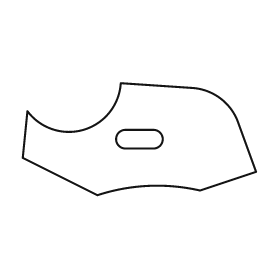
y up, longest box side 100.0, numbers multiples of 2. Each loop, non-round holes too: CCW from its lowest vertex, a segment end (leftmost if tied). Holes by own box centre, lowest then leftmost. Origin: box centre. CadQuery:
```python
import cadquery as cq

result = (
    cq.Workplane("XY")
    .moveTo(-18.0, -24.0)
    .threePointArc((4.0, -20.0), (26.0, -22.0))
    .lineTo(50.0, -14.0)
    .lineTo(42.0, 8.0)
    .threePointArc((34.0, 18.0), (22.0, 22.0))
    .lineTo(-8.0, 24.0)
    .threePointArc((-24.0, 4.0), (-48.0, 12.0))
    .lineTo(-50.0, -8.0)
    .close()
    .moveTo(-6.0, -4.0)
    .lineTo(6.0, -4.0)
    .threePointArc((10.0, 0.0), (6.0, 4.0))
    .lineTo(-6.0, 4.0)
    .threePointArc((-10.0, 0.0), (-6.0, -4.0))
    .close()
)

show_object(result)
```